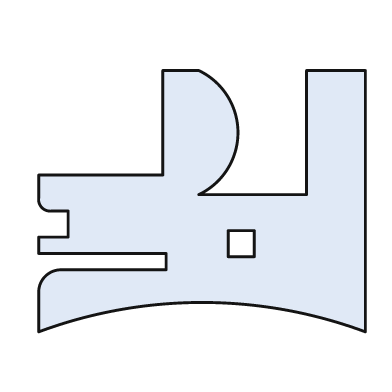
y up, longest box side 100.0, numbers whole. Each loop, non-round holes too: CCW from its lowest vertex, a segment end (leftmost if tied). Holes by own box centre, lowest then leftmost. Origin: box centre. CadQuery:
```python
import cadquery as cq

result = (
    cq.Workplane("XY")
    .moveTo(-50.0, -40.0)
    .threePointArc((0.0, -31.0), (50.0, -40.0))
    .lineTo(50.0, 40.0)
    .lineTo(32.0, 40.0)
    .lineTo(32.0, 2.0)
    .lineTo(-1.0, 2.0)
    .threePointArc((11.0, 21.0), (-1.0, 40.0))
    .lineTo(-12.0, 40.0)
    .lineTo(-12.0, 8.0)
    .lineTo(-50.0, 8.0)
    .lineTo(-50.0, 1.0)
    .threePointArc((-49.0, -2.0), (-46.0, -3.0))
    .lineTo(-41.0, -3.0)
    .lineTo(-41.0, -11.0)
    .lineTo(-50.0, -11.0)
    .lineTo(-50.0, -16.0)
    .lineTo(-11.0, -16.0)
    .lineTo(-11.0, -21.0)
    .lineTo(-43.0, -21.0)
    .threePointArc((-48.0, -23.0), (-50.0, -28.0))
    .close()
    .moveTo(8.0, -17.0)
    .lineTo(16.0, -17.0)
    .lineTo(16.0, -9.0)
    .lineTo(8.0, -9.0)
    .close()
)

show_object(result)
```